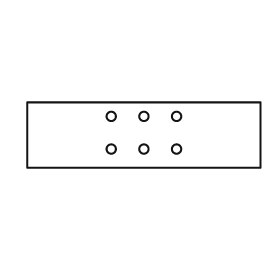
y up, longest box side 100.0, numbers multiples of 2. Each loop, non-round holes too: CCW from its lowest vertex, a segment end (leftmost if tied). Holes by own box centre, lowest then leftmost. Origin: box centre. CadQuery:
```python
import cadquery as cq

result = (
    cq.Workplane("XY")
    .moveTo(-50.0, -14.0)
    .lineTo(50.0, -14.0)
    .lineTo(50.0, 14.0)
    .lineTo(-50.0, 14.0)
    .close()
    .moveTo(-14.0, -6.0)
    .circle(2.0)
    .moveTo(0.0, -6.0)
    .circle(2.0)
    .moveTo(14.0, -6.0)
    .circle(2.0)
    .moveTo(-14.0, 8.0)
    .circle(2.0)
    .moveTo(0.0, 8.0)
    .circle(2.0)
    .moveTo(14.0, 8.0)
    .circle(2.0)
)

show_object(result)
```